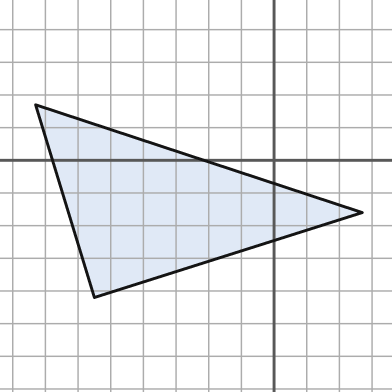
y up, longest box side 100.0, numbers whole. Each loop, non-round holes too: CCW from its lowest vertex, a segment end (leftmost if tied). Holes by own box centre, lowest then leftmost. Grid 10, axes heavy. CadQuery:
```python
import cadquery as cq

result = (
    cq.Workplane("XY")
    .moveTo(-55.0, -42.0)
    .lineTo(27.0, -16.0)
    .lineTo(-73.0, 17.0)
    .close()
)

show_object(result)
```